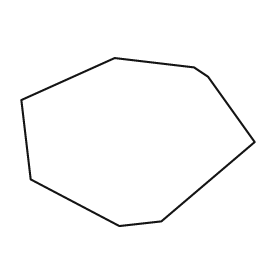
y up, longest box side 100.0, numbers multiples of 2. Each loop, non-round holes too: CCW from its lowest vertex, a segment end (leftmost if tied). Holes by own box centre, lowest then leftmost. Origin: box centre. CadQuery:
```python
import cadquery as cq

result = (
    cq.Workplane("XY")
    .moveTo(-8.0, -36.0)
    .lineTo(10.0, -34.0)
    .lineTo(50.0, 0.0)
    .lineTo(30.0, 28.0)
    .lineTo(24.0, 32.0)
    .lineTo(-10.0, 36.0)
    .lineTo(-50.0, 18.0)
    .lineTo(-46.0, -16.0)
    .close()
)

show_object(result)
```